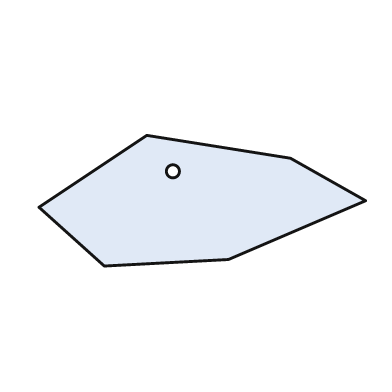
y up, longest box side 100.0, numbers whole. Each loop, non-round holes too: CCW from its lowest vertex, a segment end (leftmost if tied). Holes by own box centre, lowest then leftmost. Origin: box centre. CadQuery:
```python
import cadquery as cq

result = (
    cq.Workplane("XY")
    .moveTo(-30.0, -20.0)
    .lineTo(8.0, -18.0)
    .lineTo(50.0, 0.0)
    .lineTo(27.0, 13.0)
    .lineTo(-17.0, 20.0)
    .lineTo(-50.0, -2.0)
    .close()
    .moveTo(-9.0, 9.0)
    .circle(2.0)
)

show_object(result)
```